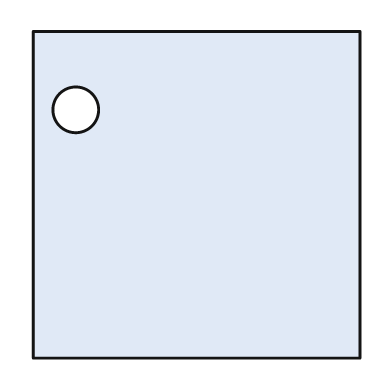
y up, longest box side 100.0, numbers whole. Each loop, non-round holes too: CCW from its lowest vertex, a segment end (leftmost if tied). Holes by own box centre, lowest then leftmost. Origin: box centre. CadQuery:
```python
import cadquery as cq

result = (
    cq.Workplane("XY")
    .moveTo(-50.0, -50.0)
    .lineTo(50.0, -50.0)
    .lineTo(50.0, 50.0)
    .lineTo(-50.0, 50.0)
    .close()
    .moveTo(-37.0, 26.0)
    .circle(7.0)
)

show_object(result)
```